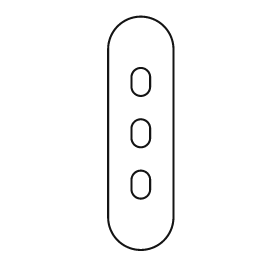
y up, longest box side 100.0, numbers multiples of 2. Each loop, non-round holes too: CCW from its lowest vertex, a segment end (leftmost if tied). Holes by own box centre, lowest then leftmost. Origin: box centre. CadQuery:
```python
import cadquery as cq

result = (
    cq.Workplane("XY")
    .moveTo(-14.0, -36.0)
    .threePointArc((0.0, -50.0), (14.0, -36.0))
    .lineTo(14.0, 36.0)
    .threePointArc((0.0, 50.0), (-14.0, 36.0))
    .close()
    .moveTo(-4.0, -24.0)
    .threePointArc((0.0, -28.0), (4.0, -24.0))
    .lineTo(4.0, -20.0)
    .threePointArc((0.0, -16.0), (-4.0, -20.0))
    .close()
    .moveTo(-4.0, -2.0)
    .threePointArc((0.0, -6.0), (4.0, -2.0))
    .lineTo(4.0, 2.0)
    .threePointArc((0.0, 6.0), (-4.0, 2.0))
    .close()
    .moveTo(-4.0, 20.0)
    .threePointArc((0.0, 16.0), (4.0, 20.0))
    .lineTo(4.0, 24.0)
    .threePointArc((0.0, 28.0), (-4.0, 24.0))
    .close()
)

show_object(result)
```